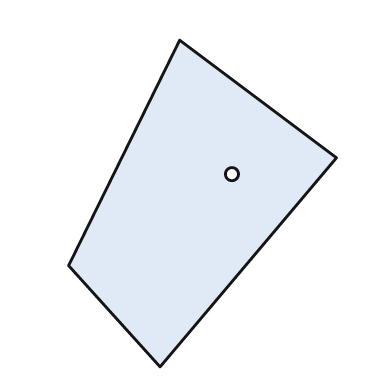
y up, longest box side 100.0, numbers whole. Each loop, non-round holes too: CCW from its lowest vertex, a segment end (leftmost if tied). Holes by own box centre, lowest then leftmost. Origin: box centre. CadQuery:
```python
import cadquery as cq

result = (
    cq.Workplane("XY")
    .moveTo(-13.0, -50.0)
    .lineTo(41.0, 14.0)
    .lineTo(-7.0, 50.0)
    .lineTo(-41.0, -19.0)
    .close()
    .moveTo(9.0, 9.0)
    .circle(2.0)
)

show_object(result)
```